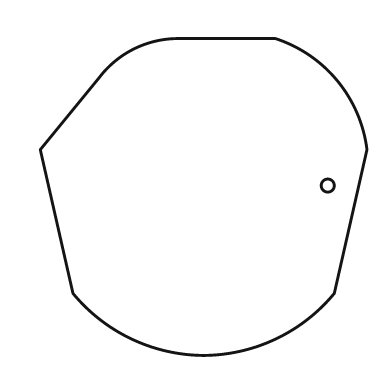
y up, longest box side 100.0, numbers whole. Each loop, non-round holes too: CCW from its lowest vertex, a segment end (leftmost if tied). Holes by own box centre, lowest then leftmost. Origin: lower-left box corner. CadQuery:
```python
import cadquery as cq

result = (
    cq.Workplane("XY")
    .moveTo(50.0, 0.0)
    .threePointArc((72.0, 5.0), (90.0, 19.0))
    .lineTo(100.0, 63.0)
    .threePointArc((91.0, 84.0), (72.0, 97.0))
    .lineTo(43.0, 97.0)
    .threePointArc((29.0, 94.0), (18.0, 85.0))
    .lineTo(0.0, 63.0)
    .lineTo(10.0, 19.0)
    .threePointArc((28.0, 5.0), (50.0, 0.0))
    .close()
    .moveTo(88.0, 52.0)
    .circle(2.0)
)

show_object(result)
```